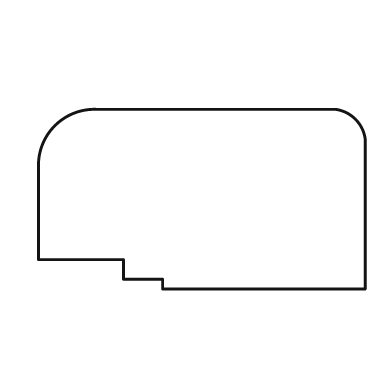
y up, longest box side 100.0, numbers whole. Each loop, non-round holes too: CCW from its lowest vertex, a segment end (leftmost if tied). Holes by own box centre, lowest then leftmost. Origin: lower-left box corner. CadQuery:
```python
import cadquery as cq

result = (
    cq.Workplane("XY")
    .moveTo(38.0, 0.0)
    .lineTo(100.0, 0.0)
    .lineTo(100.0, 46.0)
    .threePointArc((97.0, 52.0), (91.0, 55.0))
    .lineTo(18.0, 55.0)
    .threePointArc((5.0, 50.0), (0.0, 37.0))
    .lineTo(0.0, 9.0)
    .lineTo(26.0, 9.0)
    .lineTo(26.0, 3.0)
    .lineTo(38.0, 3.0)
    .close()
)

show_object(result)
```